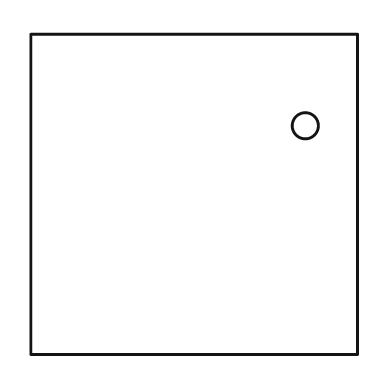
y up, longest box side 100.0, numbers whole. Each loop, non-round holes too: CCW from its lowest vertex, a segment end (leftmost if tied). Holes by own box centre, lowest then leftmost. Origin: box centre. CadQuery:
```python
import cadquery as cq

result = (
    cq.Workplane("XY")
    .moveTo(-50.0, -49.0)
    .lineTo(50.0, -49.0)
    .lineTo(50.0, 49.0)
    .lineTo(-50.0, 49.0)
    .close()
    .moveTo(34.0, 21.0)
    .circle(4.0)
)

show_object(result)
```